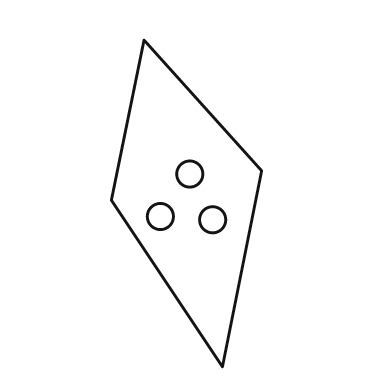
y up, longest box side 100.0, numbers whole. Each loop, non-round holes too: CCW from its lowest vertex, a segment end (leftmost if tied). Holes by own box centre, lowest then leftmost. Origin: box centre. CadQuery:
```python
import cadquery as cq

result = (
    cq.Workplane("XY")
    .moveTo(11.0, -50.0)
    .lineTo(23.0, 10.0)
    .lineTo(-13.0, 50.0)
    .lineTo(-23.0, 1.0)
    .close()
    .moveTo(8.0, -5.0)
    .circle(4.0)
    .moveTo(-8.0, -4.0)
    .circle(4.0)
    .moveTo(1.0, 9.0)
    .circle(4.0)
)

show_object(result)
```